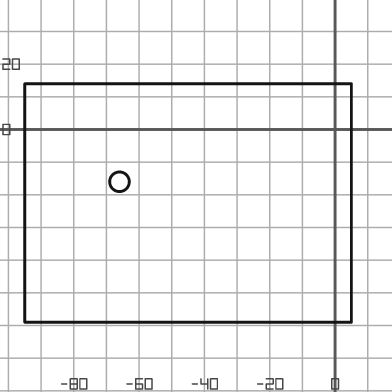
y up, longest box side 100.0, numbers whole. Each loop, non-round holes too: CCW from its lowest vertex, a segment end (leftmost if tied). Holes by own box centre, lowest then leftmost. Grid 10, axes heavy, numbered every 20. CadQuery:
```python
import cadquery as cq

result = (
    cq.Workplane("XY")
    .moveTo(-95.0, -59.0)
    .lineTo(5.0, -59.0)
    .lineTo(5.0, 14.0)
    .lineTo(-95.0, 14.0)
    .close()
    .moveTo(-66.0, -16.0)
    .circle(3.0)
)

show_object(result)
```